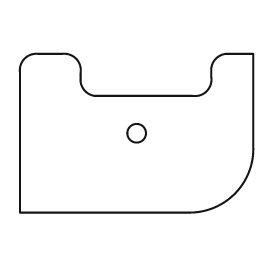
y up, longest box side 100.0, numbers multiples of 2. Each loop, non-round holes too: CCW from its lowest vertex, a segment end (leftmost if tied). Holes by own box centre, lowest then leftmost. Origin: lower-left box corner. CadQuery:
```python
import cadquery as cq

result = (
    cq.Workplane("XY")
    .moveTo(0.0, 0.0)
    .lineTo(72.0, 0.0)
    .threePointArc((92.0, 8.0), (100.0, 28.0))
    .lineTo(100.0, 68.0)
    .lineTo(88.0, 68.0)
    .threePointArc((84.0, 66.0), (82.0, 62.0))
    .lineTo(82.0, 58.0)
    .threePointArc((80.0, 52.0), (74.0, 50.0))
    .lineTo(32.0, 50.0)
    .threePointArc((28.0, 52.0), (26.0, 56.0))
    .lineTo(26.0, 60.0)
    .threePointArc((24.0, 66.0), (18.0, 68.0))
    .lineTo(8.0, 68.0)
    .threePointArc((2.0, 66.0), (0.0, 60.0))
    .close()
    .moveTo(50.0, 34.0)
    .circle(4.0)
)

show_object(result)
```